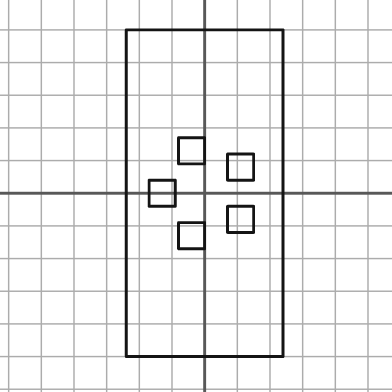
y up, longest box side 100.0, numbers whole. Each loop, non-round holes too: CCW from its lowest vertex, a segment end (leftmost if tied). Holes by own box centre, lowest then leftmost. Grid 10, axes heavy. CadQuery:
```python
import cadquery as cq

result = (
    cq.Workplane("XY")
    .moveTo(-24.0, -50.0)
    .lineTo(24.0, -50.0)
    .lineTo(24.0, 50.0)
    .lineTo(-24.0, 50.0)
    .close()
    .moveTo(-8.0, -17.0)
    .lineTo(0.0, -17.0)
    .lineTo(0.0, -9.0)
    .lineTo(-8.0, -9.0)
    .close()
    .moveTo(7.0, -12.0)
    .lineTo(15.0, -12.0)
    .lineTo(15.0, -4.0)
    .lineTo(7.0, -4.0)
    .close()
    .moveTo(-17.0, -4.0)
    .lineTo(-9.0, -4.0)
    .lineTo(-9.0, 4.0)
    .lineTo(-17.0, 4.0)
    .close()
    .moveTo(7.0, 4.0)
    .lineTo(15.0, 4.0)
    .lineTo(15.0, 12.0)
    .lineTo(7.0, 12.0)
    .close()
    .moveTo(-8.0, 9.0)
    .lineTo(0.0, 9.0)
    .lineTo(0.0, 17.0)
    .lineTo(-8.0, 17.0)
    .close()
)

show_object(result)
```